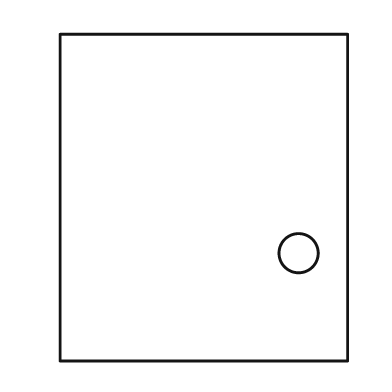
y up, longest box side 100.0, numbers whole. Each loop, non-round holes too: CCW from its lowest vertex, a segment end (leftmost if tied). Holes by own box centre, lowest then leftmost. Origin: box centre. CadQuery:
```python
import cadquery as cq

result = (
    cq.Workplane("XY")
    .moveTo(-44.0, -50.0)
    .lineTo(44.0, -50.0)
    .lineTo(44.0, 50.0)
    .lineTo(-44.0, 50.0)
    .close()
    .moveTo(29.0, -17.0)
    .circle(6.0)
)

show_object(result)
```